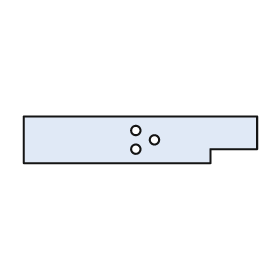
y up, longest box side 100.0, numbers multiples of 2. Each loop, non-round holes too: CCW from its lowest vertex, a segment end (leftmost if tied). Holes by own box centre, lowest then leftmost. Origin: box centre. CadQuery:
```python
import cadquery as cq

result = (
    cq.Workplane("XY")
    .moveTo(-50.0, -10.0)
    .lineTo(30.0, -10.0)
    .lineTo(30.0, -4.0)
    .lineTo(50.0, -4.0)
    .lineTo(50.0, 10.0)
    .lineTo(-50.0, 10.0)
    .close()
    .moveTo(-2.0, -4.0)
    .circle(2.0)
    .moveTo(6.0, 0.0)
    .circle(2.0)
    .moveTo(-2.0, 4.0)
    .circle(2.0)
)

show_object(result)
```